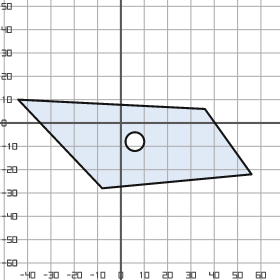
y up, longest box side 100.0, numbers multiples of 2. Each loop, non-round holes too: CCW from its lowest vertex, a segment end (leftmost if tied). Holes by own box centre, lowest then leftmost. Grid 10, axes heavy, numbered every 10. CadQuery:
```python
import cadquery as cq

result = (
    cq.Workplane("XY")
    .moveTo(-8.0, -28.0)
    .lineTo(56.0, -22.0)
    .lineTo(36.0, 6.0)
    .lineTo(-44.0, 10.0)
    .close()
    .moveTo(6.0, -8.0)
    .circle(4.0)
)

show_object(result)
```